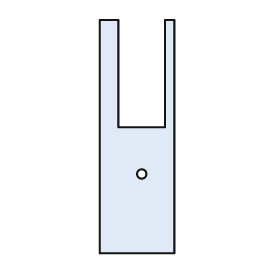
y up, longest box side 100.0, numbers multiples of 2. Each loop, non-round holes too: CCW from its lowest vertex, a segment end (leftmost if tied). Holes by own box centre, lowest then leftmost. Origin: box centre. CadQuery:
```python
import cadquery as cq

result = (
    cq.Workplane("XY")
    .moveTo(-16.0, -50.0)
    .lineTo(16.0, -50.0)
    .lineTo(16.0, 50.0)
    .lineTo(12.0, 50.0)
    .lineTo(12.0, 4.0)
    .lineTo(-8.0, 4.0)
    .lineTo(-8.0, 50.0)
    .lineTo(-16.0, 50.0)
    .close()
    .moveTo(2.0, -16.0)
    .circle(2.0)
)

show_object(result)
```